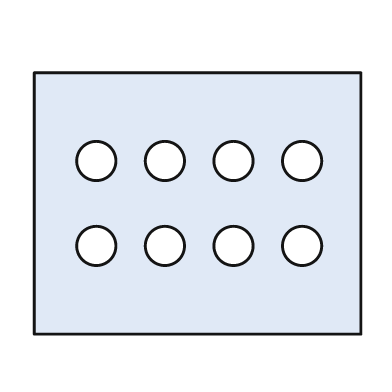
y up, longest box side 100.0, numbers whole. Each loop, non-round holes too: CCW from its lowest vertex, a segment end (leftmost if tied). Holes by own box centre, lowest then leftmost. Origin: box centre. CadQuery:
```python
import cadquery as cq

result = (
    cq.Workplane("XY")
    .moveTo(-50.0, -40.0)
    .lineTo(50.0, -40.0)
    .lineTo(50.0, 40.0)
    .lineTo(-50.0, 40.0)
    .close()
    .moveTo(-31.0, -13.0)
    .circle(6.0)
    .moveTo(-10.0, -13.0)
    .circle(6.0)
    .moveTo(11.0, -13.0)
    .circle(6.0)
    .moveTo(32.0, -13.0)
    .circle(6.0)
    .moveTo(-31.0, 13.0)
    .circle(6.0)
    .moveTo(-10.0, 13.0)
    .circle(6.0)
    .moveTo(11.0, 13.0)
    .circle(6.0)
    .moveTo(32.0, 13.0)
    .circle(6.0)
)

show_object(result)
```